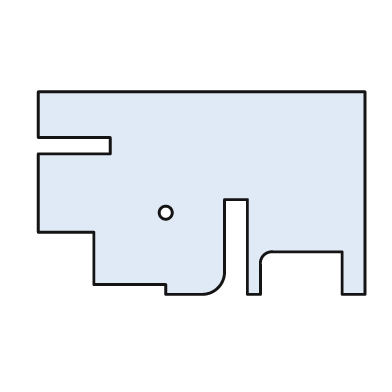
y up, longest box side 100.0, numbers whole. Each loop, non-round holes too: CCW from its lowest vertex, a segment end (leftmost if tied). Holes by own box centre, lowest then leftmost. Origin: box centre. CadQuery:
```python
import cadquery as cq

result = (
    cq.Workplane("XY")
    .moveTo(-11.0, -31.0)
    .lineTo(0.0, -31.0)
    .threePointArc((5.0, -29.0), (7.0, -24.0))
    .lineTo(7.0, -2.0)
    .lineTo(14.0, -2.0)
    .lineTo(14.0, -31.0)
    .lineTo(18.0, -31.0)
    .lineTo(18.0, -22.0)
    .threePointArc((19.0, -19.0), (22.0, -18.0))
    .lineTo(43.0, -18.0)
    .lineTo(43.0, -31.0)
    .lineTo(50.0, -31.0)
    .lineTo(50.0, 31.0)
    .lineTo(-50.0, 31.0)
    .lineTo(-50.0, 17.0)
    .lineTo(-28.0, 17.0)
    .lineTo(-28.0, 12.0)
    .lineTo(-50.0, 12.0)
    .lineTo(-50.0, -12.0)
    .lineTo(-33.0, -12.0)
    .lineTo(-33.0, -28.0)
    .lineTo(-11.0, -28.0)
    .close()
    .moveTo(-11.0, -6.0)
    .circle(2.0)
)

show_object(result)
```